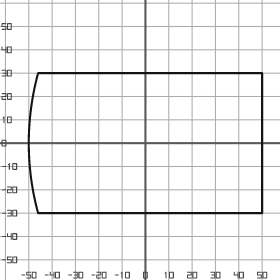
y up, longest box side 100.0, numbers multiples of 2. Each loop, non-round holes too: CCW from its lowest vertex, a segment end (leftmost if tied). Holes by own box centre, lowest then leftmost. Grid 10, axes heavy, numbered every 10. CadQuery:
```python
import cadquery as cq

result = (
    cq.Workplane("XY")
    .moveTo(-46.0, -30.0)
    .lineTo(50.0, -30.0)
    .lineTo(50.0, 30.0)
    .lineTo(-46.0, 30.0)
    .threePointArc((-50.0, 0.0), (-46.0, -30.0))
    .close()
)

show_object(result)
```